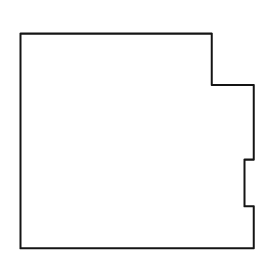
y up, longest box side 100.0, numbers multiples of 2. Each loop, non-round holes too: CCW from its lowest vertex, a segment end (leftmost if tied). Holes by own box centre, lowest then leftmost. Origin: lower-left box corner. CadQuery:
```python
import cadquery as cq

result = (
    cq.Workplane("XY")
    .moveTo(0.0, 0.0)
    .lineTo(100.0, 0.0)
    .lineTo(100.0, 18.0)
    .lineTo(96.0, 18.0)
    .lineTo(96.0, 38.0)
    .lineTo(100.0, 38.0)
    .lineTo(100.0, 70.0)
    .lineTo(82.0, 70.0)
    .lineTo(82.0, 92.0)
    .lineTo(0.0, 92.0)
    .close()
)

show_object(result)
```